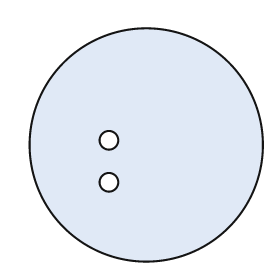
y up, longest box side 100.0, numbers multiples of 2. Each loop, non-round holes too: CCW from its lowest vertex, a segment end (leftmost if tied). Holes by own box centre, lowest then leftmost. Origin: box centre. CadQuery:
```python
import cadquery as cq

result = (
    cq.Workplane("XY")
    .moveTo(0.0, 0.0)
    .circle(50.0)
    .moveTo(-16.0, -16.0)
    .circle(4.0)
    .moveTo(-16.0, 2.0)
    .circle(4.0)
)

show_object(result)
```